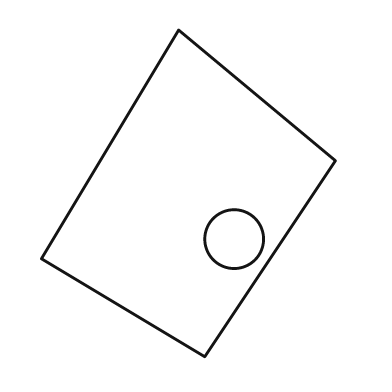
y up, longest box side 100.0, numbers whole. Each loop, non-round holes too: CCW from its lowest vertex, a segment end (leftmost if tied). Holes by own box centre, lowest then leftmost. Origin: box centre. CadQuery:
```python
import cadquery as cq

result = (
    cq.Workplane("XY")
    .moveTo(5.0, -50.0)
    .lineTo(45.0, 10.0)
    .lineTo(-3.0, 50.0)
    .lineTo(-45.0, -20.0)
    .close()
    .moveTo(14.0, -14.0)
    .circle(9.0)
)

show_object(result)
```